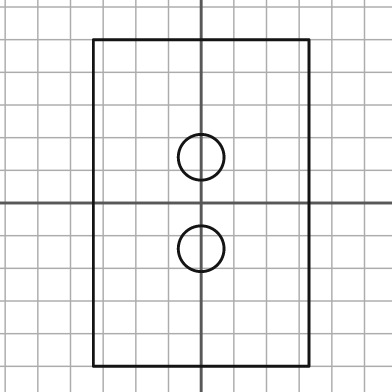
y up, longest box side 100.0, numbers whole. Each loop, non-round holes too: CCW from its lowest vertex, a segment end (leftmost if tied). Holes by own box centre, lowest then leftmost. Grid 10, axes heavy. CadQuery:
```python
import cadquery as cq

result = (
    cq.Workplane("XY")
    .moveTo(-33.0, -50.0)
    .lineTo(33.0, -50.0)
    .lineTo(33.0, 50.0)
    .lineTo(-33.0, 50.0)
    .close()
    .moveTo(0.0, -14.0)
    .circle(7.0)
    .moveTo(0.0, 14.0)
    .circle(7.0)
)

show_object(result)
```